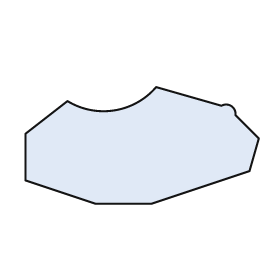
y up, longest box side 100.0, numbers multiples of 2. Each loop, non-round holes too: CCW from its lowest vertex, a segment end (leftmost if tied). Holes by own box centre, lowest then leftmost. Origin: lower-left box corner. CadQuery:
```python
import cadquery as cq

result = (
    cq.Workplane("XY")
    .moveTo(30.0, 0.0)
    .lineTo(54.0, 0.0)
    .lineTo(96.0, 14.0)
    .lineTo(100.0, 28.0)
    .lineTo(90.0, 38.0)
    .threePointArc((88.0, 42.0), (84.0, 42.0))
    .lineTo(56.0, 50.0)
    .threePointArc((38.0, 40.0), (18.0, 44.0))
    .lineTo(0.0, 30.0)
    .lineTo(0.0, 10.0)
    .close()
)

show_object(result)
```